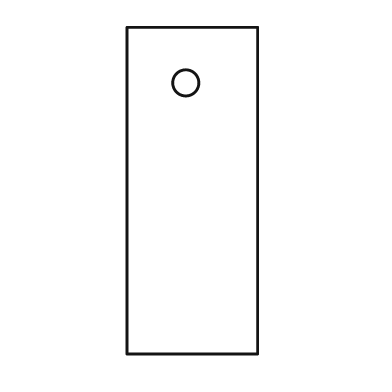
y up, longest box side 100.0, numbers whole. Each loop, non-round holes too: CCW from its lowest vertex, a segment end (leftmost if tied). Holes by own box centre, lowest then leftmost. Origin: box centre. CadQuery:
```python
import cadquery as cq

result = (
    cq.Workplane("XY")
    .moveTo(-20.0, -50.0)
    .lineTo(20.0, -50.0)
    .lineTo(20.0, 50.0)
    .lineTo(-20.0, 50.0)
    .close()
    .moveTo(-2.0, 33.0)
    .circle(4.0)
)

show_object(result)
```